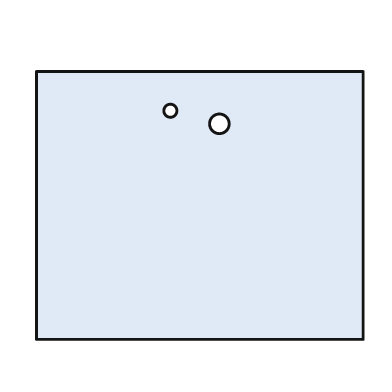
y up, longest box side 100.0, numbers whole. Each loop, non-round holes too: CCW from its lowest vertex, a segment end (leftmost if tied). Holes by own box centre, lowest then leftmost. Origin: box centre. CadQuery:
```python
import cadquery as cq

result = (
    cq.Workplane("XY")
    .moveTo(-50.0, -41.0)
    .lineTo(50.0, -41.0)
    .lineTo(50.0, 41.0)
    .lineTo(-50.0, 41.0)
    .close()
    .moveTo(6.0, 25.0)
    .circle(3.0)
    .moveTo(-9.0, 29.0)
    .circle(2.0)
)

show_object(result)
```